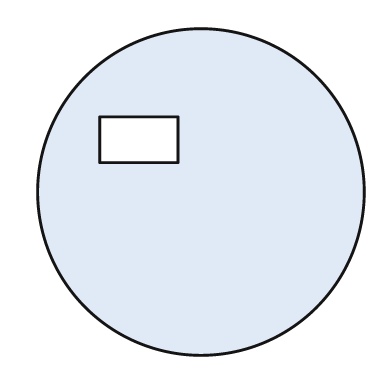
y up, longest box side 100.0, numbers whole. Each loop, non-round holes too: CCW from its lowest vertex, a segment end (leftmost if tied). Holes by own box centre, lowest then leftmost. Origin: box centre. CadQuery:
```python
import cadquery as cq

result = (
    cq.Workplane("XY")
    .moveTo(0.0, 0.0)
    .circle(50.0)
    .moveTo(-31.0, 9.0)
    .lineTo(-7.0, 9.0)
    .lineTo(-7.0, 23.0)
    .lineTo(-31.0, 23.0)
    .close()
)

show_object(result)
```